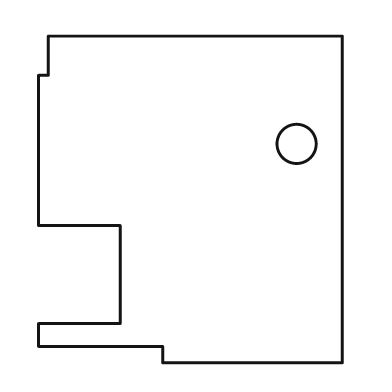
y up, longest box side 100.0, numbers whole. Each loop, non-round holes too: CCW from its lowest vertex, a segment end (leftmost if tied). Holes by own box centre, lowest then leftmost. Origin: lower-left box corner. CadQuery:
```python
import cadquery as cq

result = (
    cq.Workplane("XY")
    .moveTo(38.0, 0.0)
    .lineTo(93.0, 0.0)
    .lineTo(93.0, 100.0)
    .lineTo(3.0, 100.0)
    .lineTo(3.0, 88.0)
    .lineTo(0.0, 88.0)
    .lineTo(0.0, 42.0)
    .lineTo(25.0, 42.0)
    .lineTo(25.0, 12.0)
    .lineTo(0.0, 12.0)
    .lineTo(0.0, 5.0)
    .lineTo(38.0, 5.0)
    .close()
    .moveTo(79.0, 67.0)
    .circle(6.0)
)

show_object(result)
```